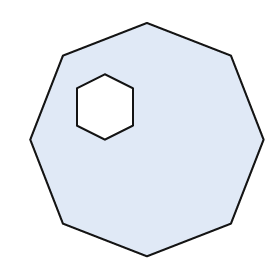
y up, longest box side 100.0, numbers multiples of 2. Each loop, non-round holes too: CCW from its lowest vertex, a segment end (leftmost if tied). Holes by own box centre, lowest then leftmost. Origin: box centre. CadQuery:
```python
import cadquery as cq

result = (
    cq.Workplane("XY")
    .moveTo(0.0, -50.0)
    .lineTo(36.0, -36.0)
    .lineTo(50.0, 0.0)
    .lineTo(36.0, 36.0)
    .lineTo(0.0, 50.0)
    .lineTo(-36.0, 36.0)
    .lineTo(-50.0, 0.0)
    .lineTo(-36.0, -36.0)
    .close()
    .moveTo(-18.0, 0.0)
    .lineTo(-6.0, 6.0)
    .lineTo(-6.0, 22.0)
    .lineTo(-18.0, 28.0)
    .lineTo(-30.0, 22.0)
    .lineTo(-30.0, 6.0)
    .close()
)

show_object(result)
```